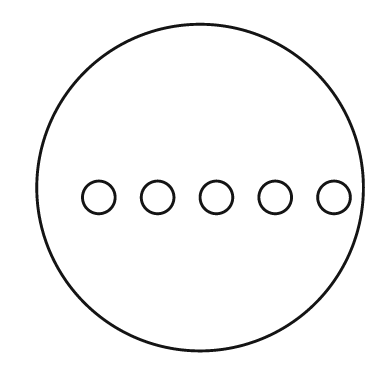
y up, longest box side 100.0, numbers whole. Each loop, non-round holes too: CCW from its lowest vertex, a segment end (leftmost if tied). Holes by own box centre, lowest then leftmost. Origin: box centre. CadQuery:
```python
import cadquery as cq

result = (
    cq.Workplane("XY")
    .moveTo(0.0, 0.0)
    .circle(50.0)
    .moveTo(-31.0, -3.0)
    .circle(5.0)
    .moveTo(-13.0, -3.0)
    .circle(5.0)
    .moveTo(5.0, -3.0)
    .circle(5.0)
    .moveTo(23.0, -3.0)
    .circle(5.0)
    .moveTo(41.0, -3.0)
    .circle(5.0)
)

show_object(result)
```